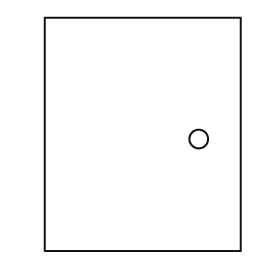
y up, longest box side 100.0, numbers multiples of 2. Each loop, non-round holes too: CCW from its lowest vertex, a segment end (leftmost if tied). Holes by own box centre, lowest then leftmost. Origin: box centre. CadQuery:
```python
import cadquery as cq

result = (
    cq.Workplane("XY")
    .moveTo(-42.0, -50.0)
    .lineTo(42.0, -50.0)
    .lineTo(42.0, 50.0)
    .lineTo(-42.0, 50.0)
    .close()
    .moveTo(24.0, -2.0)
    .circle(4.0)
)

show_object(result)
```